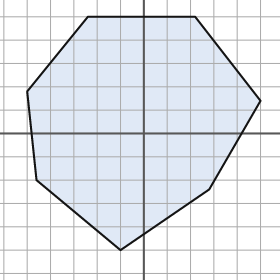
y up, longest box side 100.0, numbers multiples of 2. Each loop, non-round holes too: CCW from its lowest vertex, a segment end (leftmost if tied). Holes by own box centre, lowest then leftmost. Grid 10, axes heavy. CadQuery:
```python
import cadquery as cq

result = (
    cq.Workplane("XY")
    .moveTo(-10.0, -50.0)
    .lineTo(28.0, -24.0)
    .lineTo(50.0, 14.0)
    .lineTo(22.0, 50.0)
    .lineTo(-24.0, 50.0)
    .lineTo(-50.0, 18.0)
    .lineTo(-46.0, -20.0)
    .close()
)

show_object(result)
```